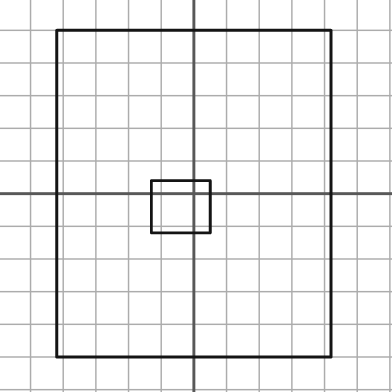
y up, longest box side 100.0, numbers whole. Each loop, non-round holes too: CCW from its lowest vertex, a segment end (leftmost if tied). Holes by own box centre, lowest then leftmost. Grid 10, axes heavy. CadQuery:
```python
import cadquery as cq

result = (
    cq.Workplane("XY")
    .moveTo(-42.0, -50.0)
    .lineTo(42.0, -50.0)
    .lineTo(42.0, 50.0)
    .lineTo(-42.0, 50.0)
    .close()
    .moveTo(-13.0, -12.0)
    .lineTo(5.0, -12.0)
    .lineTo(5.0, 4.0)
    .lineTo(-13.0, 4.0)
    .close()
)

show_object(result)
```